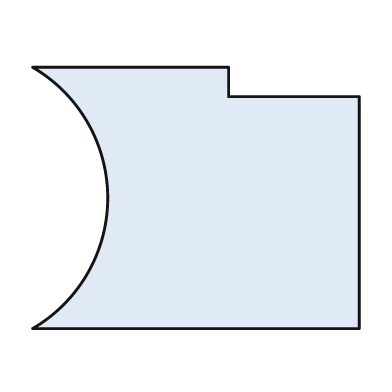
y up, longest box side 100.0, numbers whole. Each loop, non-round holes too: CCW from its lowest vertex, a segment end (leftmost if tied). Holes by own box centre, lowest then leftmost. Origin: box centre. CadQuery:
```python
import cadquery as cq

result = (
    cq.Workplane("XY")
    .moveTo(-50.0, -40.0)
    .lineTo(50.0, -40.0)
    .lineTo(50.0, 31.0)
    .lineTo(10.0, 31.0)
    .lineTo(10.0, 40.0)
    .lineTo(-50.0, 40.0)
    .threePointArc((-27.0, 0.0), (-50.0, -40.0))
    .close()
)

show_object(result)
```